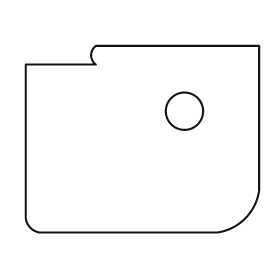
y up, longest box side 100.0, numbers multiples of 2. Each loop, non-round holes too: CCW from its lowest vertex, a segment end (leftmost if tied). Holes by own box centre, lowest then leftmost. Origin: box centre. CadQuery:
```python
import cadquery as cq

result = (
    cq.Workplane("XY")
    .moveTo(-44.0, -40.0)
    .lineTo(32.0, -40.0)
    .threePointArc((44.0, -34.0), (50.0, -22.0))
    .lineTo(50.0, 40.0)
    .lineTo(-20.0, 40.0)
    .threePointArc((-22.0, 36.0), (-20.0, 32.0))
    .lineTo(-50.0, 32.0)
    .lineTo(-50.0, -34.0)
    .threePointArc((-48.0, -38.0), (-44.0, -40.0))
    .close()
    .moveTo(18.0, 12.0)
    .circle(8.0)
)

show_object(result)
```